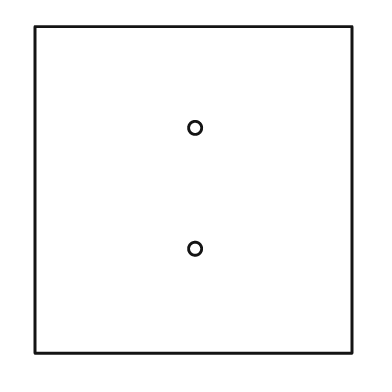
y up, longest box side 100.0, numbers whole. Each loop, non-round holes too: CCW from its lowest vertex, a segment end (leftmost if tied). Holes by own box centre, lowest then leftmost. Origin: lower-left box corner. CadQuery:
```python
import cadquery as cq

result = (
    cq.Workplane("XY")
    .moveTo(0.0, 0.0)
    .lineTo(97.0, 0.0)
    .lineTo(97.0, 100.0)
    .lineTo(0.0, 100.0)
    .close()
    .moveTo(49.0, 32.0)
    .circle(2.0)
    .moveTo(49.0, 69.0)
    .circle(2.0)
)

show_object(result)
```